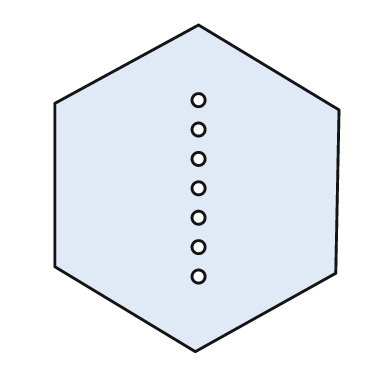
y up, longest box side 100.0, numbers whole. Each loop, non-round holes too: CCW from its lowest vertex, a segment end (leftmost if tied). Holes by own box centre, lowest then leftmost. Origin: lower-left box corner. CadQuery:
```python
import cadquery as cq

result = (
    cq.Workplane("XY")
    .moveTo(43.0, 0.0)
    .lineTo(86.0, 24.0)
    .lineTo(87.0, 74.0)
    .lineTo(44.0, 100.0)
    .lineTo(0.0, 76.0)
    .lineTo(0.0, 26.0)
    .close()
    .moveTo(44.0, 23.0)
    .circle(2.0)
    .moveTo(44.0, 32.0)
    .circle(2.0)
    .moveTo(44.0, 41.0)
    .circle(2.0)
    .moveTo(44.0, 50.0)
    .circle(2.0)
    .moveTo(44.0, 59.0)
    .circle(2.0)
    .moveTo(44.0, 68.0)
    .circle(2.0)
    .moveTo(44.0, 77.0)
    .circle(2.0)
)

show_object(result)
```